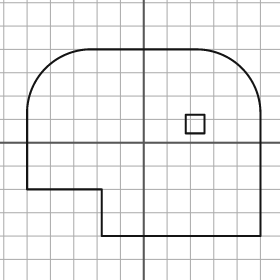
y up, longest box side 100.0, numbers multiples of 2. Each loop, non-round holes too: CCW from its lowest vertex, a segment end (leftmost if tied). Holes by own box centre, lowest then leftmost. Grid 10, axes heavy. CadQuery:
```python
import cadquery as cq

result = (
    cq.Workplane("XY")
    .moveTo(-18.0, -40.0)
    .lineTo(50.0, -40.0)
    .lineTo(50.0, 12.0)
    .threePointArc((42.0, 32.0), (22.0, 40.0))
    .lineTo(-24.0, 40.0)
    .threePointArc((-42.0, 32.0), (-50.0, 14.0))
    .lineTo(-50.0, -20.0)
    .lineTo(-18.0, -20.0)
    .close()
    .moveTo(18.0, 4.0)
    .lineTo(26.0, 4.0)
    .lineTo(26.0, 12.0)
    .lineTo(18.0, 12.0)
    .close()
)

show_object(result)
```